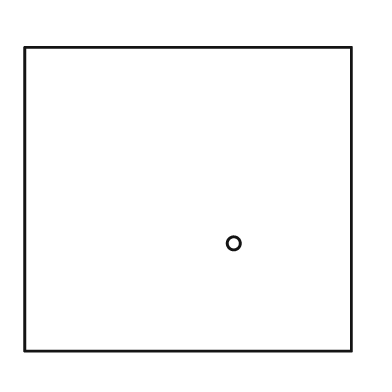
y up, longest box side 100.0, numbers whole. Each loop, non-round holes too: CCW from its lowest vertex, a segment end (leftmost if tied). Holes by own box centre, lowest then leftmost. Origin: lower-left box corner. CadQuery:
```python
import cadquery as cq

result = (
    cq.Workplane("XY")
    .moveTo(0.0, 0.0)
    .lineTo(100.0, 0.0)
    .lineTo(100.0, 93.0)
    .lineTo(0.0, 93.0)
    .close()
    .moveTo(64.0, 33.0)
    .circle(2.0)
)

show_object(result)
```